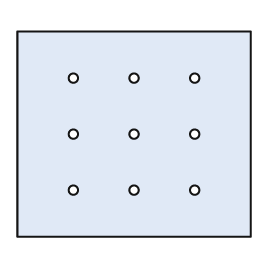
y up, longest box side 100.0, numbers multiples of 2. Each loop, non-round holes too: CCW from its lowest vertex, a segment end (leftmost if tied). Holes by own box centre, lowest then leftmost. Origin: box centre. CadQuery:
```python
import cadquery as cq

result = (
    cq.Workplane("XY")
    .moveTo(-50.0, -44.0)
    .lineTo(50.0, -44.0)
    .lineTo(50.0, 44.0)
    .lineTo(-50.0, 44.0)
    .close()
    .moveTo(-26.0, -24.0)
    .circle(2.0)
    .moveTo(0.0, -24.0)
    .circle(2.0)
    .moveTo(26.0, -24.0)
    .circle(2.0)
    .moveTo(-26.0, 0.0)
    .circle(2.0)
    .moveTo(0.0, 0.0)
    .circle(2.0)
    .moveTo(26.0, 0.0)
    .circle(2.0)
    .moveTo(-26.0, 24.0)
    .circle(2.0)
    .moveTo(0.0, 24.0)
    .circle(2.0)
    .moveTo(26.0, 24.0)
    .circle(2.0)
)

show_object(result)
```